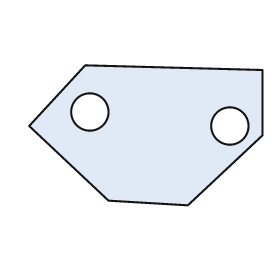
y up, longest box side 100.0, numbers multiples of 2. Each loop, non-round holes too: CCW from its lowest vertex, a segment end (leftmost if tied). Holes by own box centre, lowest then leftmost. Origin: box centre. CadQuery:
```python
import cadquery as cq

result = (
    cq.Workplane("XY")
    .moveTo(18.0, -30.0)
    .lineTo(50.0, 0.0)
    .lineTo(50.0, 28.0)
    .lineTo(-26.0, 30.0)
    .lineTo(-50.0, 4.0)
    .lineTo(-16.0, -28.0)
    .close()
    .moveTo(36.0, 4.0)
    .circle(8.0)
    .moveTo(-24.0, 10.0)
    .circle(8.0)
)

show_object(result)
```